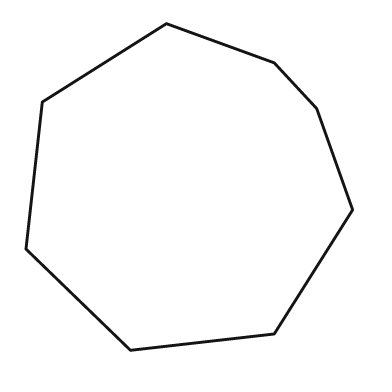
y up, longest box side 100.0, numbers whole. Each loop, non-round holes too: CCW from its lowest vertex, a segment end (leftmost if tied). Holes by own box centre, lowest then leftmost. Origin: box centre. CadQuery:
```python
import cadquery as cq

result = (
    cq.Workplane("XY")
    .moveTo(-18.0, -50.0)
    .lineTo(26.0, -45.0)
    .lineTo(50.0, -7.0)
    .lineTo(39.0, 24.0)
    .lineTo(26.0, 38.0)
    .lineTo(-7.0, 50.0)
    .lineTo(-45.0, 26.0)
    .lineTo(-50.0, -19.0)
    .close()
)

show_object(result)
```